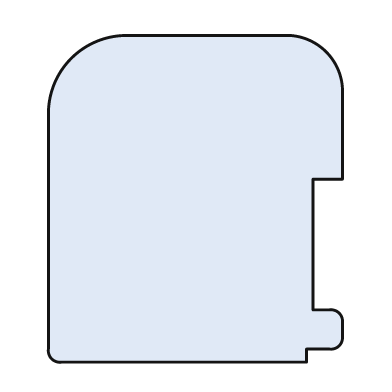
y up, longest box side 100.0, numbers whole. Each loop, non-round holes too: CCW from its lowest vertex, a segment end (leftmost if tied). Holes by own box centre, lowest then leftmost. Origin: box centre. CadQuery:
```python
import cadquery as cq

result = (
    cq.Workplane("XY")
    .moveTo(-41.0, -50.0)
    .lineTo(34.0, -50.0)
    .lineTo(34.0, -46.0)
    .lineTo(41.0, -46.0)
    .threePointArc((44.0, -45.0), (45.0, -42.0))
    .lineTo(45.0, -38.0)
    .threePointArc((44.0, -35.0), (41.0, -34.0))
    .lineTo(36.0, -34.0)
    .lineTo(36.0, 6.0)
    .lineTo(45.0, 6.0)
    .lineTo(45.0, 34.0)
    .threePointArc((40.0, 45.0), (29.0, 50.0))
    .lineTo(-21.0, 50.0)
    .threePointArc((-38.0, 43.0), (-45.0, 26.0))
    .lineTo(-45.0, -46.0)
    .threePointArc((-44.0, -49.0), (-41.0, -50.0))
    .close()
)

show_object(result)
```